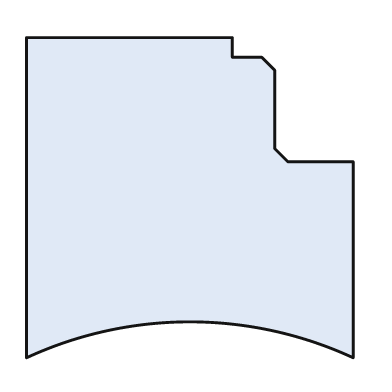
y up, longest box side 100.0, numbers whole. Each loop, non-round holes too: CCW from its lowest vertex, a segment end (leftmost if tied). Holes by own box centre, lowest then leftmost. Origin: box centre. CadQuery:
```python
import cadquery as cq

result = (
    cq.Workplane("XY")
    .moveTo(-50.0, -49.0)
    .threePointArc((0.0, -38.0), (50.0, -49.0))
    .lineTo(50.0, 11.0)
    .lineTo(30.0, 11.0)
    .lineTo(26.0, 15.0)
    .lineTo(26.0, 39.0)
    .lineTo(22.0, 43.0)
    .lineTo(13.0, 43.0)
    .lineTo(13.0, 49.0)
    .lineTo(-50.0, 49.0)
    .close()
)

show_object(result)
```